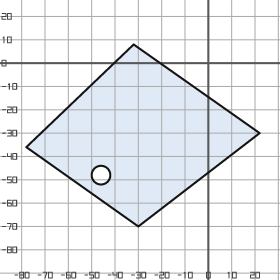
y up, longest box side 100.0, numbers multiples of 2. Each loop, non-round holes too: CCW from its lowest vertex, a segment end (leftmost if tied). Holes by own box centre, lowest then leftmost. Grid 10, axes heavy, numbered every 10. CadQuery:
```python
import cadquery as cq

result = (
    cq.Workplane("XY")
    .moveTo(-30.0, -70.0)
    .lineTo(22.0, -30.0)
    .lineTo(-32.0, 8.0)
    .lineTo(-78.0, -36.0)
    .close()
    .moveTo(-46.0, -48.0)
    .circle(4.0)
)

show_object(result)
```